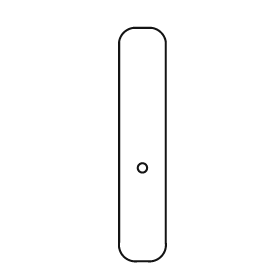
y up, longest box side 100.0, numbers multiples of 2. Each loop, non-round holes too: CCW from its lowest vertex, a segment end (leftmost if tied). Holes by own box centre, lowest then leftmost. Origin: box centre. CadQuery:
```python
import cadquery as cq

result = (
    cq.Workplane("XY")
    .moveTo(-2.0, -50.0)
    .lineTo(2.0, -50.0)
    .threePointArc((8.0, -48.0), (10.0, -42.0))
    .lineTo(10.0, 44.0)
    .threePointArc((8.0, 48.0), (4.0, 50.0))
    .lineTo(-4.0, 50.0)
    .threePointArc((-8.0, 48.0), (-10.0, 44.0))
    .lineTo(-10.0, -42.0)
    .threePointArc((-8.0, -48.0), (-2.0, -50.0))
    .close()
    .moveTo(0.0, -10.0)
    .circle(2.0)
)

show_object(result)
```